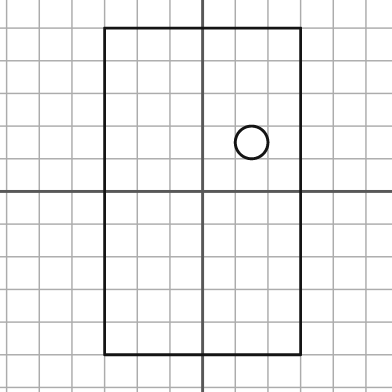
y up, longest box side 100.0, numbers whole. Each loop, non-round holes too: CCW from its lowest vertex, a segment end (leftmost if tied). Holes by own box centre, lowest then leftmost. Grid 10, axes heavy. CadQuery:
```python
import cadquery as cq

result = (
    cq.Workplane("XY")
    .moveTo(-30.0, -50.0)
    .lineTo(30.0, -50.0)
    .lineTo(30.0, 50.0)
    .lineTo(-30.0, 50.0)
    .close()
    .moveTo(15.0, 15.0)
    .circle(5.0)
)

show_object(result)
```